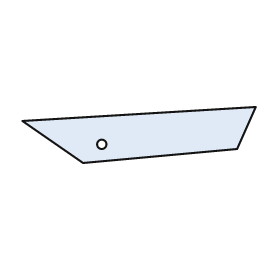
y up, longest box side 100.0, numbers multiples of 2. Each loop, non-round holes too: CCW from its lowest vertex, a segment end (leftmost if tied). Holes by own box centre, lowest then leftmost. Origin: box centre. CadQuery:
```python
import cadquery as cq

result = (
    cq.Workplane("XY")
    .moveTo(-24.0, -12.0)
    .lineTo(42.0, -6.0)
    .lineTo(50.0, 12.0)
    .lineTo(-50.0, 6.0)
    .close()
    .moveTo(-16.0, -4.0)
    .circle(2.0)
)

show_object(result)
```